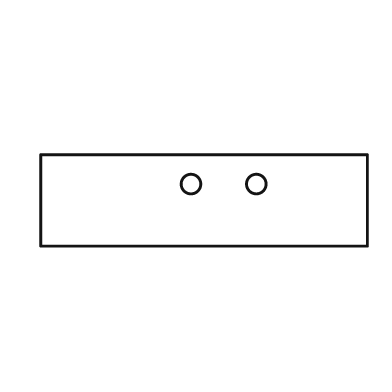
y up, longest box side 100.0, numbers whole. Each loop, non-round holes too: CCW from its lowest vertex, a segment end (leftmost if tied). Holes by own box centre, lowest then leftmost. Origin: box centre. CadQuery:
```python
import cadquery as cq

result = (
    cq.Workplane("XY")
    .moveTo(-50.0, -14.0)
    .lineTo(50.0, -14.0)
    .lineTo(50.0, 14.0)
    .lineTo(-50.0, 14.0)
    .close()
    .moveTo(-4.0, 5.0)
    .circle(3.0)
    .moveTo(16.0, 5.0)
    .circle(3.0)
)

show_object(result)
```